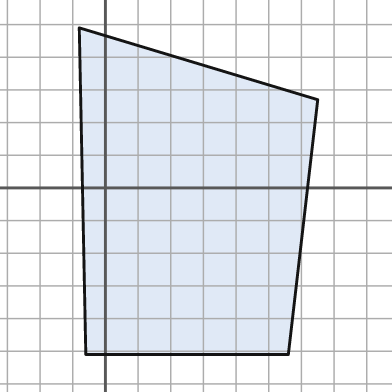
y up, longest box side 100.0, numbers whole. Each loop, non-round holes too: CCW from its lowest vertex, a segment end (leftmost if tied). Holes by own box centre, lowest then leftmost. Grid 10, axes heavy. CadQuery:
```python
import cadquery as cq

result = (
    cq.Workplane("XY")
    .moveTo(-6.0, -51.0)
    .lineTo(56.0, -51.0)
    .lineTo(65.0, 27.0)
    .lineTo(-8.0, 49.0)
    .close()
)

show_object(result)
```